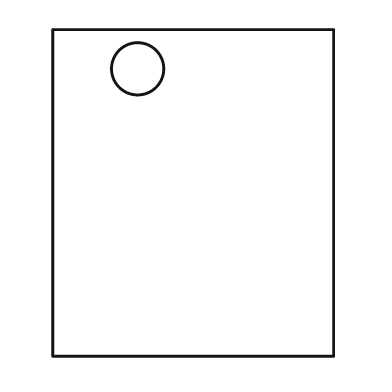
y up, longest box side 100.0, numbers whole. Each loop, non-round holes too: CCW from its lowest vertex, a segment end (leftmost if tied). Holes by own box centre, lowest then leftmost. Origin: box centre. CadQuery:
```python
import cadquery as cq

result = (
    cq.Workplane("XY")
    .moveTo(-43.0, -50.0)
    .lineTo(43.0, -50.0)
    .lineTo(43.0, 50.0)
    .lineTo(-43.0, 50.0)
    .close()
    .moveTo(-17.0, 38.0)
    .circle(8.0)
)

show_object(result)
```